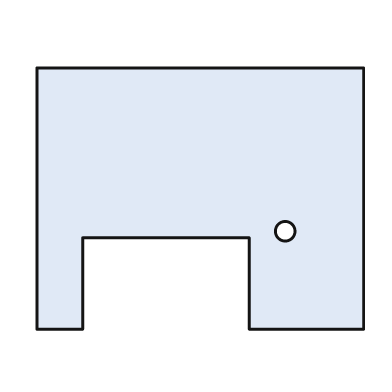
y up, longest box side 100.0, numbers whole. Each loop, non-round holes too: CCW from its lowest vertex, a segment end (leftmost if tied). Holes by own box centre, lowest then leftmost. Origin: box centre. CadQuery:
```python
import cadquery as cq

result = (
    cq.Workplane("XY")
    .moveTo(-50.0, -40.0)
    .lineTo(-36.0, -40.0)
    .lineTo(-36.0, -12.0)
    .lineTo(15.0, -12.0)
    .lineTo(15.0, -40.0)
    .lineTo(50.0, -40.0)
    .lineTo(50.0, 40.0)
    .lineTo(-50.0, 40.0)
    .close()
    .moveTo(26.0, -10.0)
    .circle(3.0)
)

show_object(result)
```